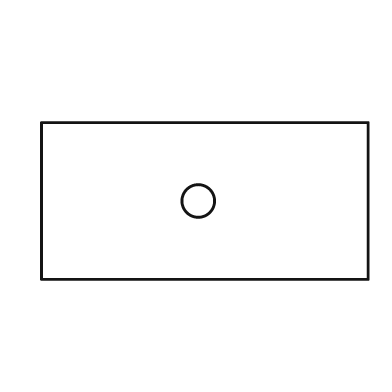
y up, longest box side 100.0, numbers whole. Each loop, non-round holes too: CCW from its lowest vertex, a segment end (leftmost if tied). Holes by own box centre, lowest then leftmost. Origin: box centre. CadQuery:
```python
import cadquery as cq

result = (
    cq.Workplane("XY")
    .moveTo(-50.0, -24.0)
    .lineTo(50.0, -24.0)
    .lineTo(50.0, 24.0)
    .lineTo(-50.0, 24.0)
    .close()
    .moveTo(-2.0, 0.0)
    .circle(5.0)
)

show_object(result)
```